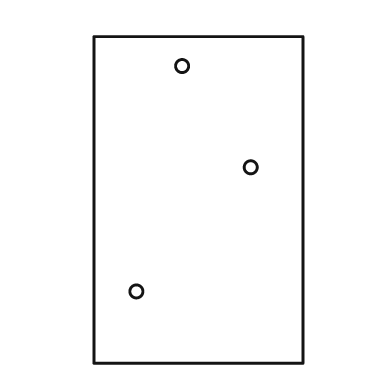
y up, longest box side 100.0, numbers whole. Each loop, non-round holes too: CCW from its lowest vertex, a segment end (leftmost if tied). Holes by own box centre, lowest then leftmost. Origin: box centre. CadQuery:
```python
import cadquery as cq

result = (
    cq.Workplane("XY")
    .moveTo(-32.0, -50.0)
    .lineTo(32.0, -50.0)
    .lineTo(32.0, 50.0)
    .lineTo(-32.0, 50.0)
    .close()
    .moveTo(-19.0, -28.0)
    .circle(2.0)
    .moveTo(16.0, 10.0)
    .circle(2.0)
    .moveTo(-5.0, 41.0)
    .circle(2.0)
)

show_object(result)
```